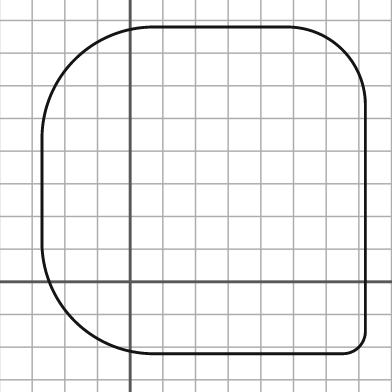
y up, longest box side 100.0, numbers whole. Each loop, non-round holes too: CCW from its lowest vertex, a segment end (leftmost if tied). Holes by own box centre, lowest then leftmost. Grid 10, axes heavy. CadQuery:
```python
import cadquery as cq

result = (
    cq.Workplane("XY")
    .moveTo(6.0, -22.0)
    .lineTo(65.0, -22.0)
    .threePointArc((70.0, -20.0), (72.0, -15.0))
    .lineTo(72.0, 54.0)
    .threePointArc((65.0, 71.0), (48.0, 78.0))
    .lineTo(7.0, 78.0)
    .threePointArc((-17.0, 68.0), (-27.0, 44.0))
    .lineTo(-27.0, 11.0)
    .threePointArc((-17.0, -12.0), (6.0, -22.0))
    .close()
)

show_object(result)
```